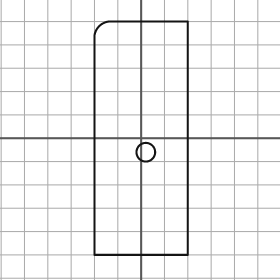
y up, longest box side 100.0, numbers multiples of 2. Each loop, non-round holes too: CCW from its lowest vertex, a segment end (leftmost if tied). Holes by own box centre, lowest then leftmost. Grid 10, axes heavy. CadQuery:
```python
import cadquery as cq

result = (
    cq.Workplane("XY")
    .moveTo(-20.0, -50.0)
    .lineTo(20.0, -50.0)
    .lineTo(20.0, 50.0)
    .lineTo(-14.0, 50.0)
    .threePointArc((-18.0, 48.0), (-20.0, 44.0))
    .close()
    .moveTo(2.0, -6.0)
    .circle(4.0)
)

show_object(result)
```